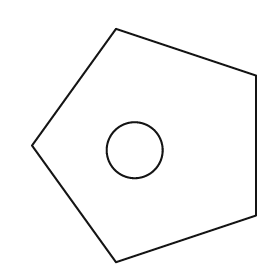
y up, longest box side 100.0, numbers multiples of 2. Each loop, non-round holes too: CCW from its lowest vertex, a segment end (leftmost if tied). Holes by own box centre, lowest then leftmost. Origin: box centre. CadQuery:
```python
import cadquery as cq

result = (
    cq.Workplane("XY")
    .moveTo(-12.0, -50.0)
    .lineTo(48.0, -30.0)
    .lineTo(48.0, 30.0)
    .lineTo(-12.0, 50.0)
    .lineTo(-48.0, 0.0)
    .close()
    .moveTo(-4.0, -2.0)
    .circle(12.0)
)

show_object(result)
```